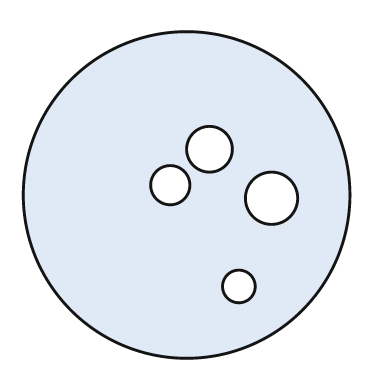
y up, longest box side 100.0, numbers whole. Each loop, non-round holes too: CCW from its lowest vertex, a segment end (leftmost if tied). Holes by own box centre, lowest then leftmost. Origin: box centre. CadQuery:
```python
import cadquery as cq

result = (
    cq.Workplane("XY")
    .moveTo(0.0, 0.0)
    .circle(50.0)
    .moveTo(16.0, -28.0)
    .circle(5.0)
    .moveTo(26.0, -1.0)
    .circle(8.0)
    .moveTo(-5.0, 3.0)
    .circle(6.0)
    .moveTo(7.0, 14.0)
    .circle(7.0)
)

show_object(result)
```